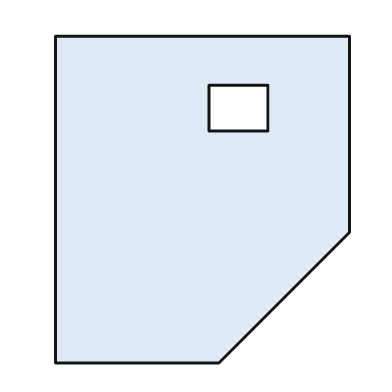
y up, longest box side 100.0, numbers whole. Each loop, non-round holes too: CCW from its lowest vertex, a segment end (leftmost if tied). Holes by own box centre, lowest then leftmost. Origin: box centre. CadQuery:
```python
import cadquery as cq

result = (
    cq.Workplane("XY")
    .moveTo(-45.0, -50.0)
    .lineTo(5.0, -50.0)
    .lineTo(45.0, -10.0)
    .lineTo(45.0, 50.0)
    .lineTo(-45.0, 50.0)
    .close()
    .moveTo(2.0, 21.0)
    .lineTo(20.0, 21.0)
    .lineTo(20.0, 35.0)
    .lineTo(2.0, 35.0)
    .close()
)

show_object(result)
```